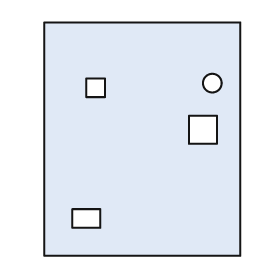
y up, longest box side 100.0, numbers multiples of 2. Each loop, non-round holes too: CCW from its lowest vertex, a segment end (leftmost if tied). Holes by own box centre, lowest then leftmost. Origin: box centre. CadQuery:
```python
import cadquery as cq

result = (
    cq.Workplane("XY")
    .moveTo(-42.0, -50.0)
    .lineTo(42.0, -50.0)
    .lineTo(42.0, 50.0)
    .lineTo(-42.0, 50.0)
    .close()
    .moveTo(-30.0, -38.0)
    .lineTo(-18.0, -38.0)
    .lineTo(-18.0, -30.0)
    .lineTo(-30.0, -30.0)
    .close()
    .moveTo(20.0, -2.0)
    .lineTo(32.0, -2.0)
    .lineTo(32.0, 10.0)
    .lineTo(20.0, 10.0)
    .close()
    .moveTo(-24.0, 18.0)
    .lineTo(-16.0, 18.0)
    .lineTo(-16.0, 26.0)
    .lineTo(-24.0, 26.0)
    .close()
    .moveTo(30.0, 24.0)
    .circle(4.0)
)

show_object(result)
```